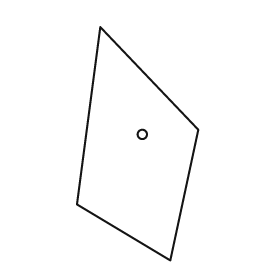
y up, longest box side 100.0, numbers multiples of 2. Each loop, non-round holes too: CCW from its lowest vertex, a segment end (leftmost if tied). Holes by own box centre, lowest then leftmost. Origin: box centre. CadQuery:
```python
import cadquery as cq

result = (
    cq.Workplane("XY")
    .moveTo(14.0, -50.0)
    .lineTo(26.0, 6.0)
    .lineTo(-16.0, 50.0)
    .lineTo(-26.0, -26.0)
    .close()
    .moveTo(2.0, 4.0)
    .circle(2.0)
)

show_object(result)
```